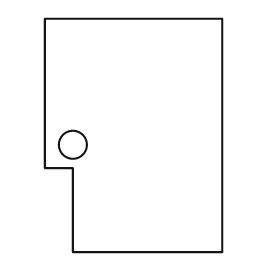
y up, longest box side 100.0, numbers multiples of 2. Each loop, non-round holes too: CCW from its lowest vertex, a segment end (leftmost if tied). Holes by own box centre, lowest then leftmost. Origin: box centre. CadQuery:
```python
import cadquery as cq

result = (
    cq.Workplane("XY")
    .moveTo(-26.0, -50.0)
    .lineTo(38.0, -50.0)
    .lineTo(38.0, 50.0)
    .lineTo(-38.0, 50.0)
    .lineTo(-38.0, -14.0)
    .lineTo(-26.0, -14.0)
    .close()
    .moveTo(-26.0, -4.0)
    .circle(6.0)
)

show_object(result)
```